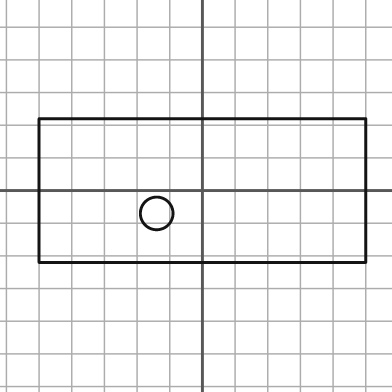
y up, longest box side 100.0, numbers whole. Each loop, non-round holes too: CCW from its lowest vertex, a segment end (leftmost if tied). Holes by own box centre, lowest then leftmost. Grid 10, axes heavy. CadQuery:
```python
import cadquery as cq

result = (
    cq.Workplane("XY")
    .moveTo(-50.0, -22.0)
    .lineTo(50.0, -22.0)
    .lineTo(50.0, 22.0)
    .lineTo(-50.0, 22.0)
    .close()
    .moveTo(-14.0, -7.0)
    .circle(5.0)
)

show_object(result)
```